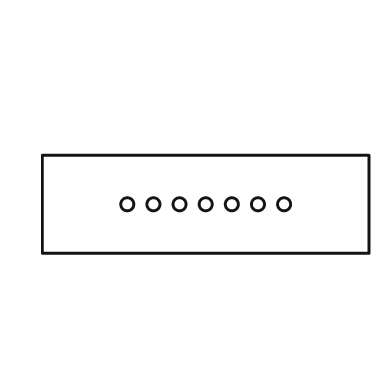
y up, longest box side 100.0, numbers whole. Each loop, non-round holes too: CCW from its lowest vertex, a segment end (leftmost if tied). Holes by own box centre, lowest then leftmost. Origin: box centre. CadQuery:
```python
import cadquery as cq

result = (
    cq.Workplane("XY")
    .moveTo(-50.0, -15.0)
    .lineTo(50.0, -15.0)
    .lineTo(50.0, 15.0)
    .lineTo(-50.0, 15.0)
    .close()
    .moveTo(-24.0, 0.0)
    .circle(2.0)
    .moveTo(-16.0, 0.0)
    .circle(2.0)
    .moveTo(-8.0, 0.0)
    .circle(2.0)
    .moveTo(0.0, 0.0)
    .circle(2.0)
    .moveTo(8.0, 0.0)
    .circle(2.0)
    .moveTo(16.0, 0.0)
    .circle(2.0)
    .moveTo(24.0, 0.0)
    .circle(2.0)
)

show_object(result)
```